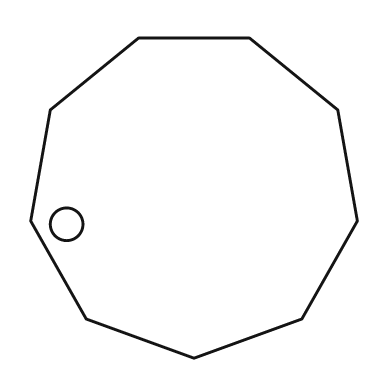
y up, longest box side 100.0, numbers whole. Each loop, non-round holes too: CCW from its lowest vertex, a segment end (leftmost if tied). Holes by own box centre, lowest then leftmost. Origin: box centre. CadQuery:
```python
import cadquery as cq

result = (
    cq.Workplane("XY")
    .moveTo(0.0, -49.0)
    .lineTo(33.0, -37.0)
    .lineTo(50.0, -7.0)
    .lineTo(44.0, 27.0)
    .lineTo(17.0, 49.0)
    .lineTo(-17.0, 49.0)
    .lineTo(-44.0, 27.0)
    .lineTo(-50.0, -7.0)
    .lineTo(-33.0, -37.0)
    .close()
    .moveTo(-39.0, -8.0)
    .circle(5.0)
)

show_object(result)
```